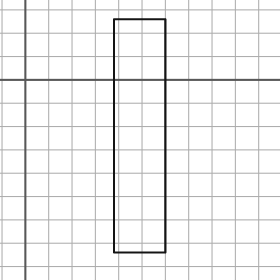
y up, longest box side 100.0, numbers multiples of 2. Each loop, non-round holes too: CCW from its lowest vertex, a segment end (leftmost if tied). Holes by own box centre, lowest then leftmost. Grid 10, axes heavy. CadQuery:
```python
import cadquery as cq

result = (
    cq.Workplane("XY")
    .moveTo(38.0, -74.0)
    .lineTo(60.0, -74.0)
    .lineTo(60.0, 26.0)
    .lineTo(38.0, 26.0)
    .close()
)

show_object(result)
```